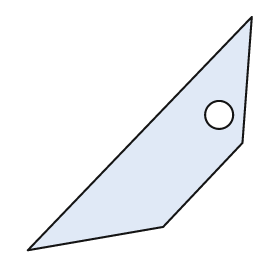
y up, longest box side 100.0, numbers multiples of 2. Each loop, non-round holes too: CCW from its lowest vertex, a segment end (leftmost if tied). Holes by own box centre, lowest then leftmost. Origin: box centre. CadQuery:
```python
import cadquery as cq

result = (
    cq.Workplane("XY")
    .moveTo(-48.0, -50.0)
    .lineTo(10.0, -40.0)
    .lineTo(44.0, -4.0)
    .lineTo(48.0, 50.0)
    .close()
    .moveTo(34.0, 8.0)
    .circle(6.0)
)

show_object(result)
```